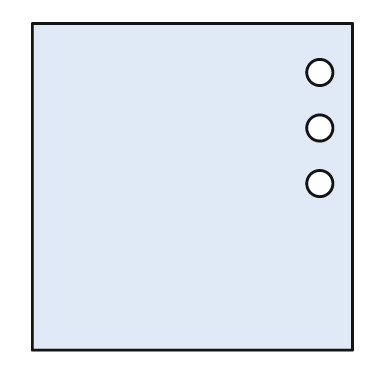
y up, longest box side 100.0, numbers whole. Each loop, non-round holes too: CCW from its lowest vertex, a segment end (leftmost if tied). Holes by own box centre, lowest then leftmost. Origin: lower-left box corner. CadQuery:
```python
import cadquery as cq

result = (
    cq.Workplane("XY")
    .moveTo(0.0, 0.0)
    .lineTo(98.0, 0.0)
    .lineTo(98.0, 100.0)
    .lineTo(0.0, 100.0)
    .close()
    .moveTo(88.0, 51.0)
    .circle(4.0)
    .moveTo(88.0, 68.0)
    .circle(4.0)
    .moveTo(88.0, 85.0)
    .circle(4.0)
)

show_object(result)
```